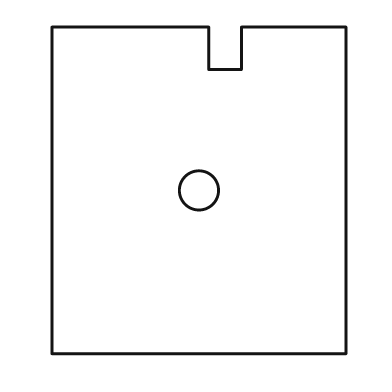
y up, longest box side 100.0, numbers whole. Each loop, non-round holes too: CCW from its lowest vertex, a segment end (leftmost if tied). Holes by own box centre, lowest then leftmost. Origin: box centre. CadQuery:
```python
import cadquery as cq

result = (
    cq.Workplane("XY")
    .moveTo(-45.0, -50.0)
    .lineTo(45.0, -50.0)
    .lineTo(45.0, 50.0)
    .lineTo(13.0, 50.0)
    .lineTo(13.0, 37.0)
    .lineTo(3.0, 37.0)
    .lineTo(3.0, 50.0)
    .lineTo(-45.0, 50.0)
    .close()
    .moveTo(0.0, 0.0)
    .circle(6.0)
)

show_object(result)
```